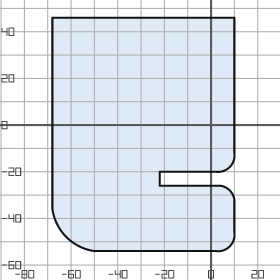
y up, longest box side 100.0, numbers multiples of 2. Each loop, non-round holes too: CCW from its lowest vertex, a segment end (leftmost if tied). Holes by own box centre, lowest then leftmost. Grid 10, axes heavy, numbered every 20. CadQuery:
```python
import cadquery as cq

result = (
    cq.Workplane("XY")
    .moveTo(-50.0, -54.0)
    .lineTo(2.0, -54.0)
    .threePointArc((8.0, -52.0), (10.0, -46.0))
    .lineTo(10.0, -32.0)
    .threePointArc((8.0, -28.0), (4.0, -26.0))
    .lineTo(-22.0, -26.0)
    .lineTo(-22.0, -20.0)
    .lineTo(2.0, -20.0)
    .threePointArc((8.0, -18.0), (10.0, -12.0))
    .lineTo(10.0, 46.0)
    .lineTo(-68.0, 46.0)
    .lineTo(-68.0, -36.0)
    .threePointArc((-62.0, -48.0), (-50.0, -54.0))
    .close()
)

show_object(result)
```